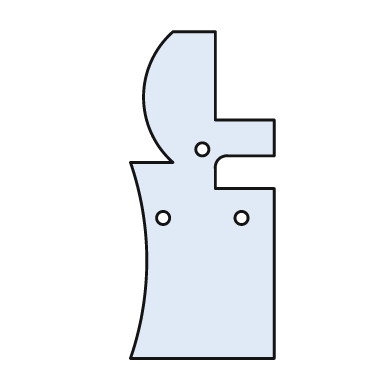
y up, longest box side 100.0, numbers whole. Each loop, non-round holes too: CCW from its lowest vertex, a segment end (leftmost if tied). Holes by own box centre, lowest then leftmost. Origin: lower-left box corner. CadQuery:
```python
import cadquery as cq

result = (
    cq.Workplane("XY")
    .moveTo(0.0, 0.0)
    .lineTo(44.0, 0.0)
    .lineTo(44.0, 52.0)
    .lineTo(26.0, 52.0)
    .lineTo(26.0, 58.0)
    .threePointArc((27.0, 61.0), (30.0, 62.0))
    .lineTo(44.0, 62.0)
    .lineTo(44.0, 73.0)
    .lineTo(26.0, 73.0)
    .lineTo(26.0, 100.0)
    .lineTo(13.0, 100.0)
    .threePointArc((4.0, 80.0), (13.0, 60.0))
    .lineTo(0.0, 60.0)
    .threePointArc((5.0, 30.0), (0.0, 0.0))
    .close()
    .moveTo(10.0, 43.0)
    .circle(2.0)
    .moveTo(34.0, 43.0)
    .circle(2.0)
    .moveTo(22.0, 64.0)
    .circle(2.0)
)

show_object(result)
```